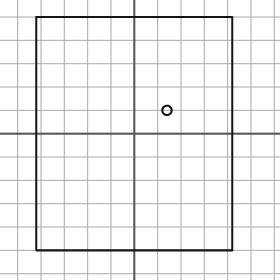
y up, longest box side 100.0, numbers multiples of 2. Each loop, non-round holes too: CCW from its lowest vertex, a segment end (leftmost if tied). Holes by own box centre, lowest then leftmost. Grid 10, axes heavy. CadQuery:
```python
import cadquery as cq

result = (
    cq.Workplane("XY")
    .moveTo(-42.0, -50.0)
    .lineTo(42.0, -50.0)
    .lineTo(42.0, 50.0)
    .lineTo(-42.0, 50.0)
    .close()
    .moveTo(14.0, 10.0)
    .circle(2.0)
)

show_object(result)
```